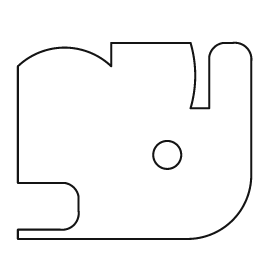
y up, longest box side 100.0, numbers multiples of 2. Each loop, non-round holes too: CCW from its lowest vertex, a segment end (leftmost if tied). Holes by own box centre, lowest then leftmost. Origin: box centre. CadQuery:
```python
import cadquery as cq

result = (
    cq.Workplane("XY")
    .moveTo(-50.0, -42.0)
    .lineTo(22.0, -42.0)
    .threePointArc((42.0, -34.0), (50.0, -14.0))
    .lineTo(50.0, 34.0)
    .threePointArc((48.0, 40.0), (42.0, 42.0))
    .lineTo(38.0, 42.0)
    .threePointArc((34.0, 40.0), (32.0, 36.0))
    .lineTo(32.0, 14.0)
    .lineTo(24.0, 14.0)
    .threePointArc((26.0, 28.0), (24.0, 42.0))
    .lineTo(-10.0, 42.0)
    .lineTo(-10.0, 32.0)
    .threePointArc((-30.0, 40.0), (-50.0, 32.0))
    .lineTo(-50.0, -18.0)
    .lineTo(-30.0, -18.0)
    .threePointArc((-26.0, -20.0), (-24.0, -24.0))
    .lineTo(-24.0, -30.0)
    .threePointArc((-26.0, -36.0), (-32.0, -38.0))
    .lineTo(-50.0, -38.0)
    .close()
    .moveTo(14.0, -6.0)
    .circle(6.0)
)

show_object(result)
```